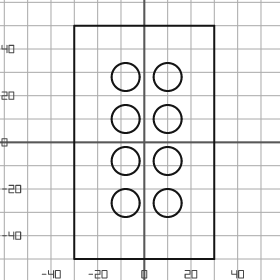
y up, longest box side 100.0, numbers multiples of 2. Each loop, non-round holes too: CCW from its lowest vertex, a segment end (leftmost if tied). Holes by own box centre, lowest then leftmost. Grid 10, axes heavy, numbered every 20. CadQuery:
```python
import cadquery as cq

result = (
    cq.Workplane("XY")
    .moveTo(-30.0, -50.0)
    .lineTo(30.0, -50.0)
    .lineTo(30.0, 50.0)
    .lineTo(-30.0, 50.0)
    .close()
    .moveTo(-8.0, -26.0)
    .circle(6.0)
    .moveTo(10.0, -26.0)
    .circle(6.0)
    .moveTo(-8.0, -8.0)
    .circle(6.0)
    .moveTo(10.0, -8.0)
    .circle(6.0)
    .moveTo(-8.0, 10.0)
    .circle(6.0)
    .moveTo(10.0, 10.0)
    .circle(6.0)
    .moveTo(-8.0, 28.0)
    .circle(6.0)
    .moveTo(10.0, 28.0)
    .circle(6.0)
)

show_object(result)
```